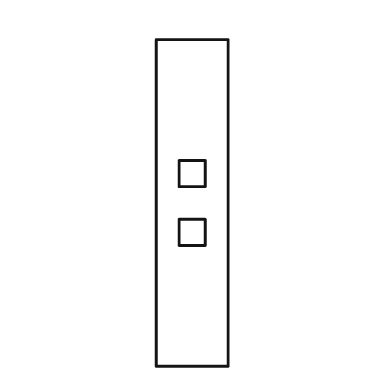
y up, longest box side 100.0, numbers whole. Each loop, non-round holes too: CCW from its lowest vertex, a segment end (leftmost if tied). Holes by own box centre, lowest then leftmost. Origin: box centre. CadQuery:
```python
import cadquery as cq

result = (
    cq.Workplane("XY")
    .moveTo(-11.0, -50.0)
    .lineTo(11.0, -50.0)
    .lineTo(11.0, 50.0)
    .lineTo(-11.0, 50.0)
    .close()
    .moveTo(-4.0, -13.0)
    .lineTo(4.0, -13.0)
    .lineTo(4.0, -5.0)
    .lineTo(-4.0, -5.0)
    .close()
    .moveTo(-4.0, 5.0)
    .lineTo(4.0, 5.0)
    .lineTo(4.0, 13.0)
    .lineTo(-4.0, 13.0)
    .close()
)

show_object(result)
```